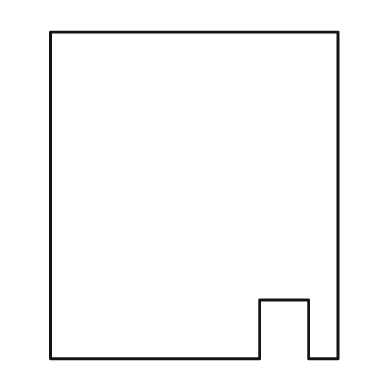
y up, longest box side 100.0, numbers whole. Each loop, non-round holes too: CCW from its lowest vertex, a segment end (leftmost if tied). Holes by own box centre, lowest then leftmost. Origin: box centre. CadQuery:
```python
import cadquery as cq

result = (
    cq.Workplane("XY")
    .moveTo(-44.0, -50.0)
    .lineTo(20.0, -50.0)
    .lineTo(20.0, -32.0)
    .lineTo(35.0, -32.0)
    .lineTo(35.0, -50.0)
    .lineTo(44.0, -50.0)
    .lineTo(44.0, 50.0)
    .lineTo(-44.0, 50.0)
    .close()
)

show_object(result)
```